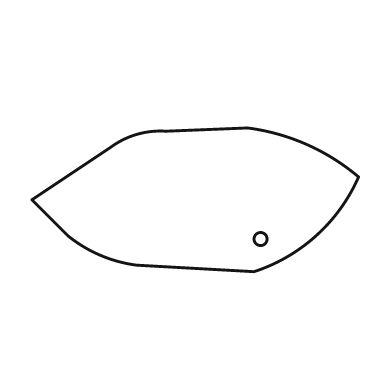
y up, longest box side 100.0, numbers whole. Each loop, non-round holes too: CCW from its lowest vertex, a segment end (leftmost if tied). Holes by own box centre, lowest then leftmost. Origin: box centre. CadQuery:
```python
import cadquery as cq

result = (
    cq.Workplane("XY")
    .moveTo(18.0, -22.0)
    .threePointArc((37.0, -11.0), (50.0, 7.0))
    .threePointArc((34.0, 17.0), (16.0, 22.0))
    .lineTo(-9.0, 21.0)
    .threePointArc((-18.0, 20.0), (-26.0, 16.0))
    .lineTo(-50.0, 0.0)
    .lineTo(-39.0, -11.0)
    .threePointArc((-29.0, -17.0), (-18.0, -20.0))
    .close()
    .moveTo(20.0, -12.0)
    .circle(2.0)
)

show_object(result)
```